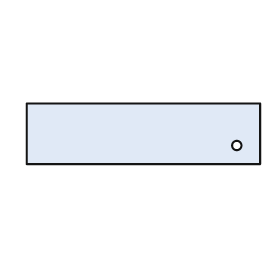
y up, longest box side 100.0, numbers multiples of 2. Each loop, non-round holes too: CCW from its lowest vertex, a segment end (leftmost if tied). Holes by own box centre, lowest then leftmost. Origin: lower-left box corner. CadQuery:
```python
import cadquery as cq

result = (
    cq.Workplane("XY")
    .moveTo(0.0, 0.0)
    .lineTo(100.0, 0.0)
    .lineTo(100.0, 26.0)
    .lineTo(0.0, 26.0)
    .close()
    .moveTo(90.0, 8.0)
    .circle(2.0)
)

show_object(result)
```